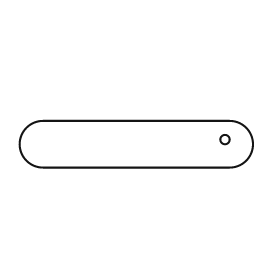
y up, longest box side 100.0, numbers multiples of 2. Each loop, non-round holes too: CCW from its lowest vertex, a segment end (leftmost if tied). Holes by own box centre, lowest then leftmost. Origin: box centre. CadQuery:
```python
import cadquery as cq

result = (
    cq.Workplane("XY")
    .moveTo(-40.0, -10.0)
    .lineTo(40.0, -10.0)
    .threePointArc((50.0, 0.0), (40.0, 10.0))
    .lineTo(-40.0, 10.0)
    .threePointArc((-50.0, 0.0), (-40.0, -10.0))
    .close()
    .moveTo(38.0, 2.0)
    .circle(2.0)
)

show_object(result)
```